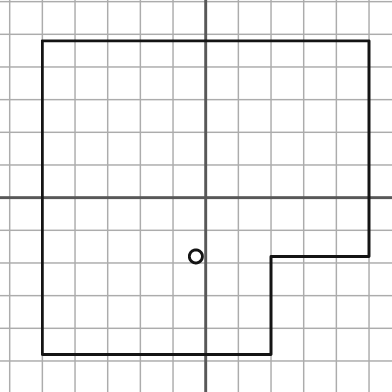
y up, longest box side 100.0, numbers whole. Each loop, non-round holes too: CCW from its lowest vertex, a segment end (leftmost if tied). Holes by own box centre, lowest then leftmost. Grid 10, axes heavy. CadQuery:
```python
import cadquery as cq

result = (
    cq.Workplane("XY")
    .moveTo(-50.0, -48.0)
    .lineTo(20.0, -48.0)
    .lineTo(20.0, -18.0)
    .lineTo(50.0, -18.0)
    .lineTo(50.0, 48.0)
    .lineTo(-50.0, 48.0)
    .close()
    .moveTo(-3.0, -18.0)
    .circle(2.0)
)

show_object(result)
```